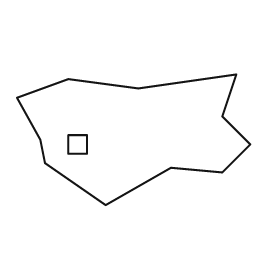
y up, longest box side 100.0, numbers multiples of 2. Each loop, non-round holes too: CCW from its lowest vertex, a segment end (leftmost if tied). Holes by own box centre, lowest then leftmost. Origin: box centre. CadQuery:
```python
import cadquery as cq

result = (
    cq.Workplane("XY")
    .moveTo(-12.0, -28.0)
    .lineTo(16.0, -12.0)
    .lineTo(38.0, -14.0)
    .lineTo(50.0, -2.0)
    .lineTo(38.0, 10.0)
    .lineTo(44.0, 28.0)
    .lineTo(2.0, 22.0)
    .lineTo(-28.0, 26.0)
    .lineTo(-50.0, 18.0)
    .lineTo(-40.0, 0.0)
    .lineTo(-38.0, -10.0)
    .close()
    .moveTo(-28.0, -6.0)
    .lineTo(-20.0, -6.0)
    .lineTo(-20.0, 2.0)
    .lineTo(-28.0, 2.0)
    .close()
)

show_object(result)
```